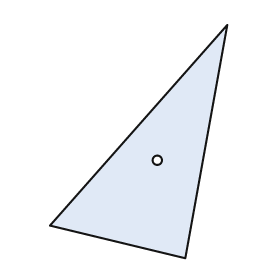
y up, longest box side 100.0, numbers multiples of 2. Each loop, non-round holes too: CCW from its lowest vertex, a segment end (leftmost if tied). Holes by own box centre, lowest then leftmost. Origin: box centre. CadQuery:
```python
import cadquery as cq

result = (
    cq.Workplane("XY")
    .moveTo(20.0, -50.0)
    .lineTo(38.0, 50.0)
    .lineTo(-38.0, -36.0)
    .close()
    .moveTo(8.0, -8.0)
    .circle(2.0)
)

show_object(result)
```